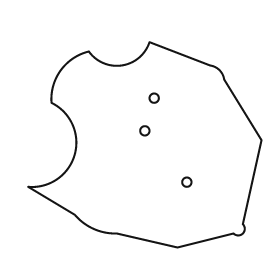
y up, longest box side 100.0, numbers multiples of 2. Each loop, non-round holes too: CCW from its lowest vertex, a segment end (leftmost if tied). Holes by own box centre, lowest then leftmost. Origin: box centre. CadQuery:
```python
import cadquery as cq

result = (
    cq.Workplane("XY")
    .moveTo(14.0, -44.0)
    .lineTo(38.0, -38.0)
    .threePointArc((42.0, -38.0), (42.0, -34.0))
    .lineTo(50.0, 2.0)
    .lineTo(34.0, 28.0)
    .threePointArc((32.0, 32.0), (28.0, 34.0))
    .lineTo(2.0, 44.0)
    .threePointArc((-10.0, 34.0), (-24.0, 40.0))
    .threePointArc((-36.0, 32.0), (-40.0, 18.0))
    .threePointArc((-30.0, -4.0), (-50.0, -18.0))
    .lineTo(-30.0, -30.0)
    .threePointArc((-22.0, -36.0), (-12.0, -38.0))
    .close()
    .moveTo(18.0, -16.0)
    .circle(2.0)
    .moveTo(0.0, 6.0)
    .circle(2.0)
    .moveTo(4.0, 20.0)
    .circle(2.0)
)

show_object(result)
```